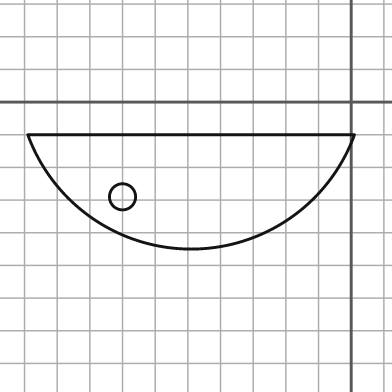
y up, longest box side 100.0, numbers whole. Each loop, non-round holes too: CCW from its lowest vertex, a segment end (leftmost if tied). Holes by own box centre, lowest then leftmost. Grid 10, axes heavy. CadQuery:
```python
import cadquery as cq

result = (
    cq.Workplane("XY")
    .moveTo(-99.0, -10.0)
    .threePointArc((-49.0, -45.0), (1.0, -10.0))
    .close()
    .moveTo(-70.0, -29.0)
    .circle(4.0)
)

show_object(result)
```